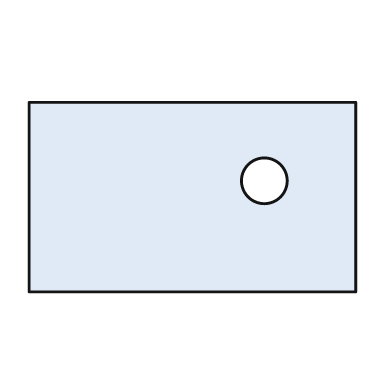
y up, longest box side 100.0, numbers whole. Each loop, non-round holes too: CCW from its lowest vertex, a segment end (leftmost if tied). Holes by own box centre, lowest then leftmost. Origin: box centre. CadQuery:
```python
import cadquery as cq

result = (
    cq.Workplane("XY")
    .moveTo(-50.0, -29.0)
    .lineTo(50.0, -29.0)
    .lineTo(50.0, 29.0)
    .lineTo(-50.0, 29.0)
    .close()
    .moveTo(22.0, 5.0)
    .circle(7.0)
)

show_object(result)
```